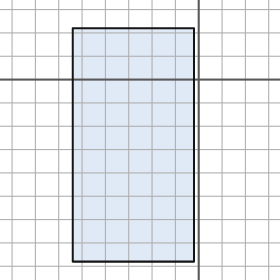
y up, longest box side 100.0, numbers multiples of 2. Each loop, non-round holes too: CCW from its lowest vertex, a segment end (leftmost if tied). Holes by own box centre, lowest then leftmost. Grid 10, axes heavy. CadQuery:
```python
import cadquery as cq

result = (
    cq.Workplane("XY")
    .moveTo(-54.0, -78.0)
    .lineTo(-2.0, -78.0)
    .lineTo(-2.0, 22.0)
    .lineTo(-54.0, 22.0)
    .close()
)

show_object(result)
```